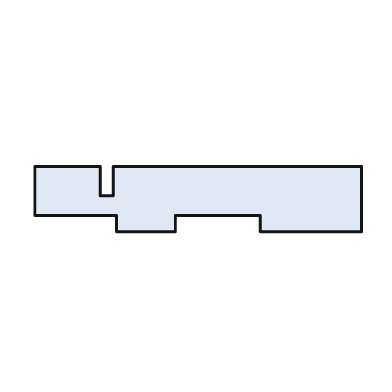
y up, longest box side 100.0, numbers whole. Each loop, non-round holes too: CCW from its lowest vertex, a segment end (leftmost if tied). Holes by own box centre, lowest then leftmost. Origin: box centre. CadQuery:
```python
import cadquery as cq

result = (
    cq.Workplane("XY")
    .moveTo(-25.0, -10.0)
    .lineTo(-7.0, -10.0)
    .lineTo(-7.0, -5.0)
    .lineTo(19.0, -5.0)
    .lineTo(19.0, -10.0)
    .lineTo(50.0, -10.0)
    .lineTo(50.0, 10.0)
    .lineTo(-26.0, 10.0)
    .lineTo(-26.0, 1.0)
    .lineTo(-30.0, 1.0)
    .lineTo(-30.0, 10.0)
    .lineTo(-50.0, 10.0)
    .lineTo(-50.0, -5.0)
    .lineTo(-25.0, -5.0)
    .close()
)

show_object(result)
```